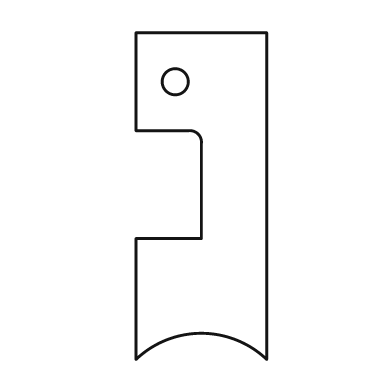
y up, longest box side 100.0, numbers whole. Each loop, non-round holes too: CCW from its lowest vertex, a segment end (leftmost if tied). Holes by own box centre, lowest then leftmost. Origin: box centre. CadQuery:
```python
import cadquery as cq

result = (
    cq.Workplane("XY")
    .moveTo(-20.0, -50.0)
    .threePointArc((0.0, -42.0), (20.0, -50.0))
    .lineTo(20.0, 50.0)
    .lineTo(-20.0, 50.0)
    .lineTo(-20.0, 20.0)
    .lineTo(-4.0, 20.0)
    .threePointArc((-1.0, 19.0), (0.0, 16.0))
    .lineTo(0.0, -13.0)
    .lineTo(-20.0, -13.0)
    .close()
    .moveTo(-8.0, 35.0)
    .circle(4.0)
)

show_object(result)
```